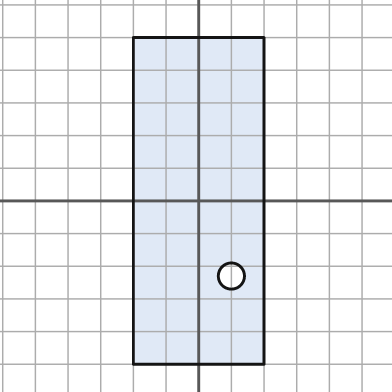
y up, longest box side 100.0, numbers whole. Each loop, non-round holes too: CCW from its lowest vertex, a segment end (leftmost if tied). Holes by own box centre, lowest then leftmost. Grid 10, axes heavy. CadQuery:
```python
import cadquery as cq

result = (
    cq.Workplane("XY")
    .moveTo(-20.0, -50.0)
    .lineTo(20.0, -50.0)
    .lineTo(20.0, 50.0)
    .lineTo(-20.0, 50.0)
    .close()
    .moveTo(10.0, -23.0)
    .circle(4.0)
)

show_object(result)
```